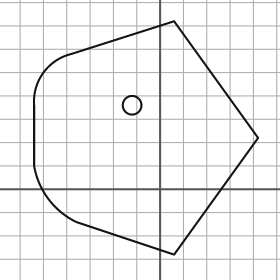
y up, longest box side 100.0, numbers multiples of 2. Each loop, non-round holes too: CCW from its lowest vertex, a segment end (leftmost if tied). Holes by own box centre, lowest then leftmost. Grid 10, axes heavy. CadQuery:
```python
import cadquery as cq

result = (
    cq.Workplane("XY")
    .moveTo(6.0, -28.0)
    .lineTo(42.0, 22.0)
    .lineTo(6.0, 72.0)
    .lineTo(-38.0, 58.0)
    .threePointArc((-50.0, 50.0), (-54.0, 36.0))
    .lineTo(-54.0, 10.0)
    .threePointArc((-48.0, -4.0), (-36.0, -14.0))
    .close()
    .moveTo(-12.0, 36.0)
    .circle(4.0)
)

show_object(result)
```